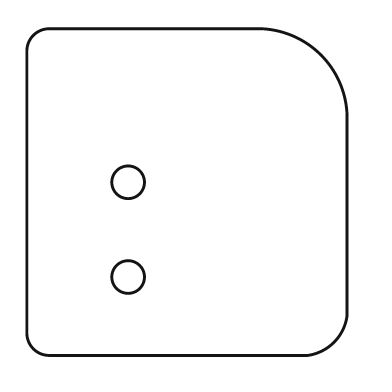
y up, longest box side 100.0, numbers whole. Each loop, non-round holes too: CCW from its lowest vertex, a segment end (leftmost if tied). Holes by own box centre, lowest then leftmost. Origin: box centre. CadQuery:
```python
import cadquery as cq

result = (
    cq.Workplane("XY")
    .moveTo(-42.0, -50.0)
    .lineTo(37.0, -50.0)
    .threePointArc((45.0, -46.0), (49.0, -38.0))
    .lineTo(49.0, 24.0)
    .threePointArc((41.0, 42.0), (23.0, 50.0))
    .lineTo(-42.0, 50.0)
    .threePointArc((-47.0, 48.0), (-49.0, 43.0))
    .lineTo(-49.0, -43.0)
    .threePointArc((-47.0, -48.0), (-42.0, -50.0))
    .close()
    .moveTo(-18.0, -26.0)
    .circle(5.0)
    .moveTo(-18.0, 3.0)
    .circle(5.0)
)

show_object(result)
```